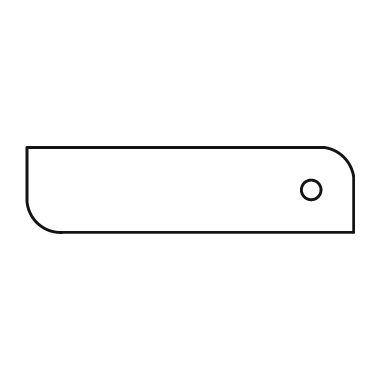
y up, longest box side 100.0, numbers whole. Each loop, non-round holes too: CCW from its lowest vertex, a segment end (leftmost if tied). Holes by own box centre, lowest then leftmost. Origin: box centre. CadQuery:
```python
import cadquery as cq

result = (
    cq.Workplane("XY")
    .moveTo(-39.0, -13.0)
    .lineTo(50.0, -13.0)
    .lineTo(50.0, 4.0)
    .threePointArc((47.0, 10.0), (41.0, 13.0))
    .lineTo(-50.0, 13.0)
    .lineTo(-50.0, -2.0)
    .threePointArc((-47.0, -10.0), (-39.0, -13.0))
    .close()
    .moveTo(37.0, 0.0)
    .circle(3.0)
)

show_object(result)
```